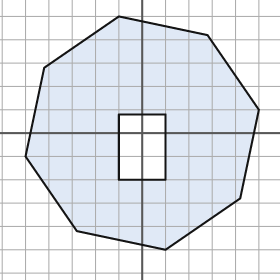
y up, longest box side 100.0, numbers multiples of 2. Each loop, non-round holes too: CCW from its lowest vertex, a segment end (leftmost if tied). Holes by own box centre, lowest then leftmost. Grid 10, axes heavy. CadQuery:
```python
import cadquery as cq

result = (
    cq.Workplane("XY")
    .moveTo(10.0, -50.0)
    .lineTo(42.0, -28.0)
    .lineTo(50.0, 10.0)
    .lineTo(28.0, 42.0)
    .lineTo(-10.0, 50.0)
    .lineTo(-42.0, 28.0)
    .lineTo(-50.0, -10.0)
    .lineTo(-28.0, -42.0)
    .close()
    .moveTo(-10.0, -20.0)
    .lineTo(10.0, -20.0)
    .lineTo(10.0, 8.0)
    .lineTo(-10.0, 8.0)
    .close()
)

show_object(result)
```